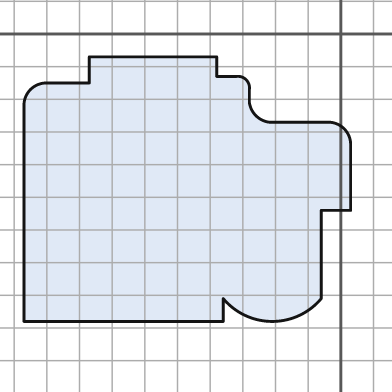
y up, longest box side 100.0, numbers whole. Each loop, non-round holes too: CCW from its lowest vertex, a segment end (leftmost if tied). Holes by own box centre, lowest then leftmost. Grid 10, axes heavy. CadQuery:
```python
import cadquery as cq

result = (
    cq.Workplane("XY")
    .moveTo(-97.0, -88.0)
    .lineTo(-36.0, -88.0)
    .lineTo(-36.0, -81.0)
    .threePointArc((-21.0, -88.0), (-6.0, -81.0))
    .lineTo(-6.0, -54.0)
    .lineTo(3.0, -54.0)
    .lineTo(3.0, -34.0)
    .threePointArc((1.0, -29.0), (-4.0, -27.0))
    .lineTo(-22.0, -27.0)
    .threePointArc((-26.0, -25.0), (-28.0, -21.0))
    .lineTo(-28.0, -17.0)
    .threePointArc((-29.0, -14.0), (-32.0, -13.0))
    .lineTo(-38.0, -13.0)
    .lineTo(-38.0, -7.0)
    .lineTo(-77.0, -7.0)
    .lineTo(-77.0, -15.0)
    .lineTo(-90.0, -15.0)
    .threePointArc((-95.0, -17.0), (-97.0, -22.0))
    .close()
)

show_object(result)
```